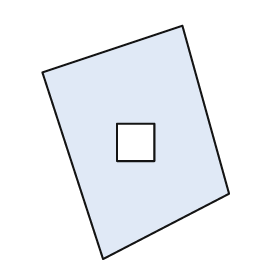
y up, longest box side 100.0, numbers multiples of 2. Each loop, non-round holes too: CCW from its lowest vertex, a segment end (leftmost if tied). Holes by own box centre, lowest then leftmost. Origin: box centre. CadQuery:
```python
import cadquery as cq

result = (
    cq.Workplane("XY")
    .moveTo(-14.0, -50.0)
    .lineTo(40.0, -22.0)
    .lineTo(20.0, 50.0)
    .lineTo(-40.0, 30.0)
    .close()
    .moveTo(-8.0, -8.0)
    .lineTo(8.0, -8.0)
    .lineTo(8.0, 8.0)
    .lineTo(-8.0, 8.0)
    .close()
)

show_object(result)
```